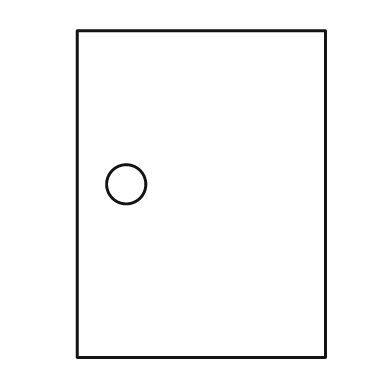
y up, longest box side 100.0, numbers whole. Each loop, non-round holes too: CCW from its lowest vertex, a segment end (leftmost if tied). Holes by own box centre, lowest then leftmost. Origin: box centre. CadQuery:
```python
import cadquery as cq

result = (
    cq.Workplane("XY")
    .moveTo(-38.0, -50.0)
    .lineTo(38.0, -50.0)
    .lineTo(38.0, 50.0)
    .lineTo(-38.0, 50.0)
    .close()
    .moveTo(-23.0, 3.0)
    .circle(6.0)
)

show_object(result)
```